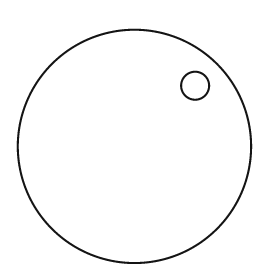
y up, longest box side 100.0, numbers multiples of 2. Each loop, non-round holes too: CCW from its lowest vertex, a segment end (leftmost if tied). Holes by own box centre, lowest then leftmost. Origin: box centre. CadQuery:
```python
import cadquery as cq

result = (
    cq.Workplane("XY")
    .moveTo(0.0, 0.0)
    .circle(50.0)
    .moveTo(26.0, 26.0)
    .circle(6.0)
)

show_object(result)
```